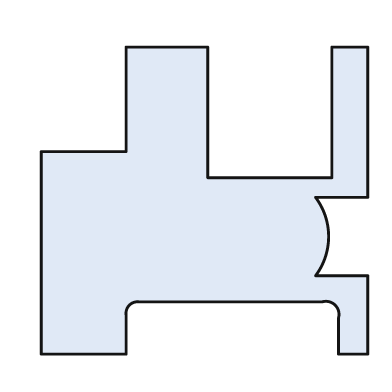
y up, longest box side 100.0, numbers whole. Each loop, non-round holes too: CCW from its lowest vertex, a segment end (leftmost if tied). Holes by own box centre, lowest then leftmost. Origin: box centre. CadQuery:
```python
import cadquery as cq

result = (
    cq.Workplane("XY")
    .moveTo(-50.0, -47.0)
    .lineTo(-24.0, -47.0)
    .lineTo(-24.0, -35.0)
    .threePointArc((-23.0, -32.0), (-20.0, -31.0))
    .lineTo(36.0, -31.0)
    .threePointArc((40.0, -32.0), (41.0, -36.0))
    .lineTo(41.0, -47.0)
    .lineTo(50.0, -47.0)
    .lineTo(50.0, -23.0)
    .lineTo(34.0, -23.0)
    .threePointArc((38.0, -11.0), (34.0, 1.0))
    .lineTo(50.0, 1.0)
    .lineTo(50.0, 47.0)
    .lineTo(39.0, 47.0)
    .lineTo(39.0, 7.0)
    .lineTo(1.0, 7.0)
    .lineTo(1.0, 47.0)
    .lineTo(-24.0, 47.0)
    .lineTo(-24.0, 15.0)
    .lineTo(-50.0, 15.0)
    .close()
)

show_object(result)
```